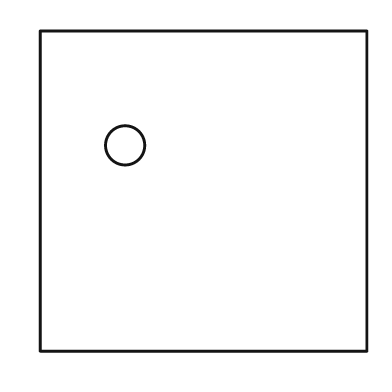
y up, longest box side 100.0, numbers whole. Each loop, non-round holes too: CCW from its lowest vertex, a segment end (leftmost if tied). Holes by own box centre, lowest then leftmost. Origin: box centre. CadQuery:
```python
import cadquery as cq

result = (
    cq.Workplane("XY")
    .moveTo(-50.0, -49.0)
    .lineTo(50.0, -49.0)
    .lineTo(50.0, 49.0)
    .lineTo(-50.0, 49.0)
    .close()
    .moveTo(-24.0, 14.0)
    .circle(6.0)
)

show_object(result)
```